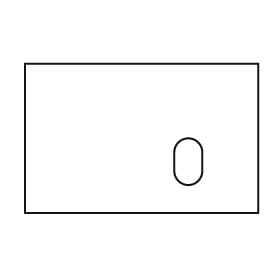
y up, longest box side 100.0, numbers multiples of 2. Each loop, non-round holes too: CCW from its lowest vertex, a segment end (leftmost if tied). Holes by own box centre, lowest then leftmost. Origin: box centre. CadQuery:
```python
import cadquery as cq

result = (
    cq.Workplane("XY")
    .moveTo(-50.0, -32.0)
    .lineTo(50.0, -32.0)
    .lineTo(50.0, 32.0)
    .lineTo(-50.0, 32.0)
    .close()
    .moveTo(14.0, -14.0)
    .threePointArc((20.0, -20.0), (26.0, -14.0))
    .lineTo(26.0, -6.0)
    .threePointArc((20.0, 0.0), (14.0, -6.0))
    .close()
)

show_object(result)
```